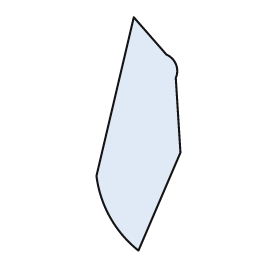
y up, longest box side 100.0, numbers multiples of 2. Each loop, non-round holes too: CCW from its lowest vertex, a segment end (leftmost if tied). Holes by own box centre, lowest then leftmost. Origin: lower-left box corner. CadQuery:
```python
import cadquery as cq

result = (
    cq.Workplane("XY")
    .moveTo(18.0, 0.0)
    .lineTo(36.0, 42.0)
    .lineTo(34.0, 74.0)
    .threePointArc((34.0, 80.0), (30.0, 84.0))
    .lineTo(16.0, 100.0)
    .lineTo(0.0, 32.0)
    .threePointArc((6.0, 14.0), (18.0, 0.0))
    .close()
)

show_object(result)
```